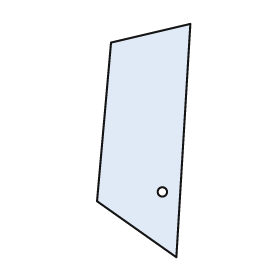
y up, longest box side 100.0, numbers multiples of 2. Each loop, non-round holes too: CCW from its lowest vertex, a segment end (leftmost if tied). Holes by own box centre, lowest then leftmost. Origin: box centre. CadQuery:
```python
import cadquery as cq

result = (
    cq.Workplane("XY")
    .moveTo(14.0, -50.0)
    .lineTo(20.0, 50.0)
    .lineTo(-14.0, 42.0)
    .lineTo(-20.0, -26.0)
    .close()
    .moveTo(8.0, -22.0)
    .circle(2.0)
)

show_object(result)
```